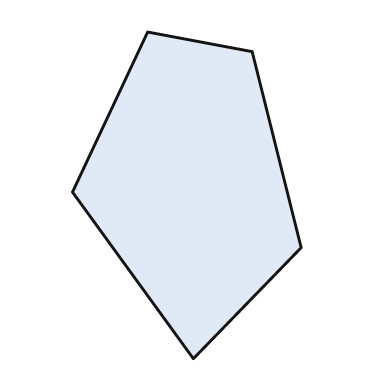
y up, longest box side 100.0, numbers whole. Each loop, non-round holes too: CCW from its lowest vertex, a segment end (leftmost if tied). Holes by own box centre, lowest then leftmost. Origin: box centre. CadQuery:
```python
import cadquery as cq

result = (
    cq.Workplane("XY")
    .moveTo(2.0, -50.0)
    .lineTo(35.0, -16.0)
    .lineTo(20.0, 44.0)
    .lineTo(-12.0, 50.0)
    .lineTo(-35.0, 1.0)
    .close()
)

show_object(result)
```